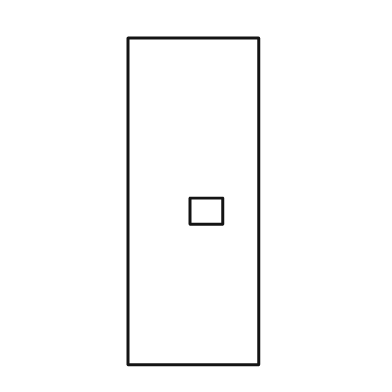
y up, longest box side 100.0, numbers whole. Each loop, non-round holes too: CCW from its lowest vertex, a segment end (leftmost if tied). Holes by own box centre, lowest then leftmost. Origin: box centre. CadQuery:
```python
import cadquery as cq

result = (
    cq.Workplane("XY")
    .moveTo(-20.0, -50.0)
    .lineTo(20.0, -50.0)
    .lineTo(20.0, 50.0)
    .lineTo(-20.0, 50.0)
    .close()
    .moveTo(-1.0, -7.0)
    .lineTo(9.0, -7.0)
    .lineTo(9.0, 1.0)
    .lineTo(-1.0, 1.0)
    .close()
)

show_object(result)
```